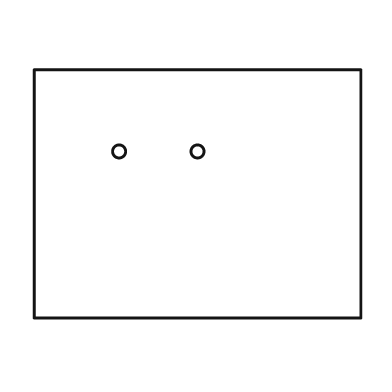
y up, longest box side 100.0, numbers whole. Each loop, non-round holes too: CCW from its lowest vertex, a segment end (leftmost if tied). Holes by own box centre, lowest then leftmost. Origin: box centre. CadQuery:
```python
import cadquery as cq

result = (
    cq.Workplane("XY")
    .moveTo(-50.0, -38.0)
    .lineTo(50.0, -38.0)
    .lineTo(50.0, 38.0)
    .lineTo(-50.0, 38.0)
    .close()
    .moveTo(-24.0, 13.0)
    .circle(2.0)
    .moveTo(0.0, 13.0)
    .circle(2.0)
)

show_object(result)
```